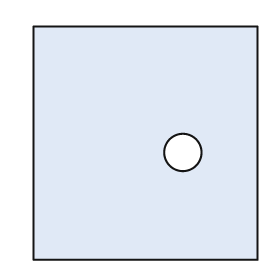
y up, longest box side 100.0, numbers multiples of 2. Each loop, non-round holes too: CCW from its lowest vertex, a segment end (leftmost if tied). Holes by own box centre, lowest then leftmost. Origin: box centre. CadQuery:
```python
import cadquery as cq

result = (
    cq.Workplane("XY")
    .moveTo(-48.0, -50.0)
    .lineTo(48.0, -50.0)
    .lineTo(48.0, 50.0)
    .lineTo(-48.0, 50.0)
    .close()
    .moveTo(16.0, -4.0)
    .circle(8.0)
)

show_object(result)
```